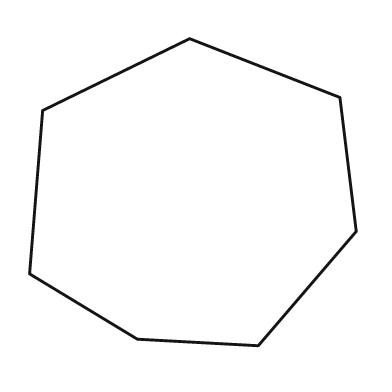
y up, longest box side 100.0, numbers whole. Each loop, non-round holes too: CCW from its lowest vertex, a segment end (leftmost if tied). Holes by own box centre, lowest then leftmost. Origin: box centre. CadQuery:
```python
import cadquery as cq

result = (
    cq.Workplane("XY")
    .moveTo(20.0, -47.0)
    .lineTo(50.0, -12.0)
    .lineTo(45.0, 29.0)
    .lineTo(-1.0, 47.0)
    .lineTo(-46.0, 25.0)
    .lineTo(-50.0, -25.0)
    .lineTo(-17.0, -45.0)
    .close()
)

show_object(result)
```